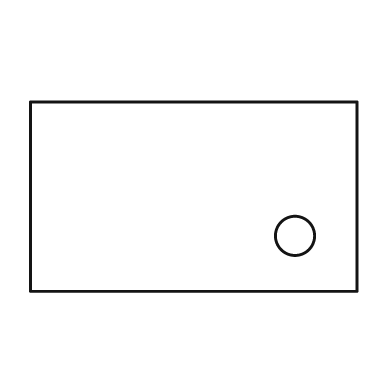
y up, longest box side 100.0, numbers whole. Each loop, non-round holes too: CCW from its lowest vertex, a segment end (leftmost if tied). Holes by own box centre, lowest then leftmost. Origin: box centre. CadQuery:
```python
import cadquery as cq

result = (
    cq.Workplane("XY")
    .moveTo(-50.0, -29.0)
    .lineTo(50.0, -29.0)
    .lineTo(50.0, 29.0)
    .lineTo(-50.0, 29.0)
    .close()
    .moveTo(31.0, -12.0)
    .circle(6.0)
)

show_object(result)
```